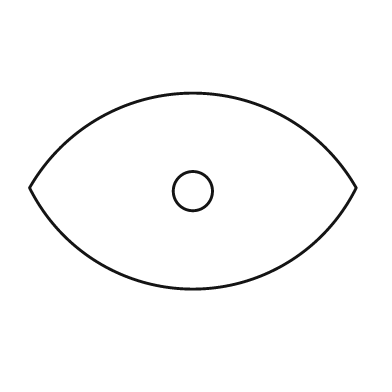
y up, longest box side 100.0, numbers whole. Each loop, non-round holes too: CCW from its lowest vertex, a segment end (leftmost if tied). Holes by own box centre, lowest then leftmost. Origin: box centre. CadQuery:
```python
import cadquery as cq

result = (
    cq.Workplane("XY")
    .moveTo(-50.0, 1.0)
    .threePointArc((0.0, -30.0), (50.0, 1.0))
    .threePointArc((0.0, 30.0), (-50.0, 1.0))
    .close()
    .moveTo(0.0, 0.0)
    .circle(6.0)
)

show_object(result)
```